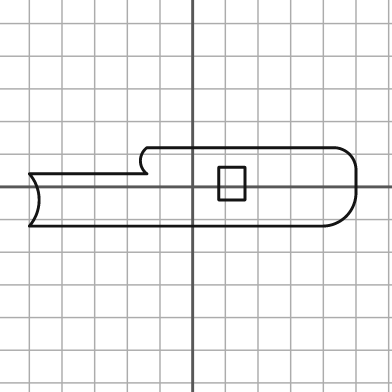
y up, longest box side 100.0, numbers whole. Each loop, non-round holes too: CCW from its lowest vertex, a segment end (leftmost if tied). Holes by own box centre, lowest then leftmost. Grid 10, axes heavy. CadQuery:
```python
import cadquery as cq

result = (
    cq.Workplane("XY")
    .moveTo(-50.0, -12.0)
    .lineTo(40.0, -12.0)
    .threePointArc((47.0, -9.0), (50.0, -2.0))
    .lineTo(50.0, 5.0)
    .threePointArc((48.0, 10.0), (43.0, 12.0))
    .lineTo(-14.0, 12.0)
    .threePointArc((-16.0, 8.0), (-14.0, 4.0))
    .lineTo(-50.0, 4.0)
    .threePointArc((-47.0, -4.0), (-50.0, -12.0))
    .close()
    .moveTo(8.0, -4.0)
    .lineTo(16.0, -4.0)
    .lineTo(16.0, 6.0)
    .lineTo(8.0, 6.0)
    .close()
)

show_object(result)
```